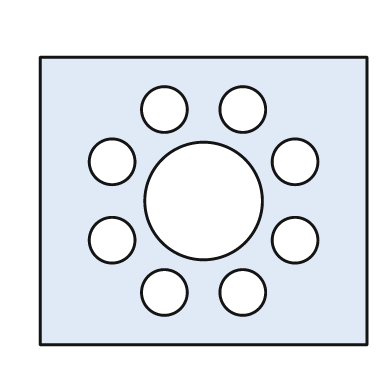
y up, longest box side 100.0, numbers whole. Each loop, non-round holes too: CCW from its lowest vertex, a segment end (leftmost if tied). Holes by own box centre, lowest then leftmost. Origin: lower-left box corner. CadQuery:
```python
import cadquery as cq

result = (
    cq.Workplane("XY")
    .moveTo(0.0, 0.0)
    .lineTo(100.0, 0.0)
    .lineTo(100.0, 88.0)
    .lineTo(0.0, 88.0)
    .close()
    .moveTo(38.0, 16.0)
    .circle(7.0)
    .moveTo(62.0, 16.0)
    .circle(7.0)
    .moveTo(22.0, 32.0)
    .circle(7.0)
    .moveTo(78.0, 32.0)
    .circle(7.0)
    .moveTo(50.0, 44.0)
    .circle(18.0)
    .moveTo(22.0, 56.0)
    .circle(7.0)
    .moveTo(78.0, 56.0)
    .circle(7.0)
    .moveTo(38.0, 72.0)
    .circle(7.0)
    .moveTo(62.0, 72.0)
    .circle(7.0)
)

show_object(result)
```